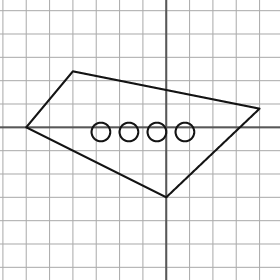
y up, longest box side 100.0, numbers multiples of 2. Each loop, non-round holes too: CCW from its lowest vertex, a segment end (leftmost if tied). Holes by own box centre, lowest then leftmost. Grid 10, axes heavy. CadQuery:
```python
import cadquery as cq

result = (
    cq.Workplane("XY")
    .moveTo(0.0, -30.0)
    .lineTo(40.0, 8.0)
    .lineTo(-40.0, 24.0)
    .lineTo(-60.0, 0.0)
    .close()
    .moveTo(-28.0, -2.0)
    .circle(4.0)
    .moveTo(-16.0, -2.0)
    .circle(4.0)
    .moveTo(-4.0, -2.0)
    .circle(4.0)
    .moveTo(8.0, -2.0)
    .circle(4.0)
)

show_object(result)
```